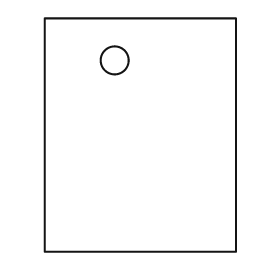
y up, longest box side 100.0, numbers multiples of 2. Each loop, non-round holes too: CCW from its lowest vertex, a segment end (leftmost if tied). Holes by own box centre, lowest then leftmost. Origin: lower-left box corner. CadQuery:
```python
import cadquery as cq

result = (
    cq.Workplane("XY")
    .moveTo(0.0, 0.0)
    .lineTo(82.0, 0.0)
    .lineTo(82.0, 100.0)
    .lineTo(0.0, 100.0)
    .close()
    .moveTo(30.0, 82.0)
    .circle(6.0)
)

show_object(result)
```